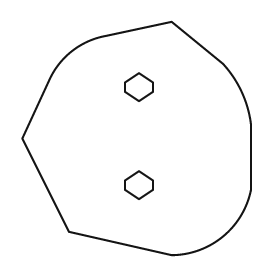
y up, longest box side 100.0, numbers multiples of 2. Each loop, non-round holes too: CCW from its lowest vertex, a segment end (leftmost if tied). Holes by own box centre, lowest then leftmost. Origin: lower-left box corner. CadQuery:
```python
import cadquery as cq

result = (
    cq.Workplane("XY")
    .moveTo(64.0, 0.0)
    .threePointArc((86.0, 8.0), (98.0, 28.0))
    .lineTo(98.0, 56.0)
    .threePointArc((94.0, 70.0), (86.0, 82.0))
    .lineTo(64.0, 100.0)
    .lineTo(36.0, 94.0)
    .threePointArc((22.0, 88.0), (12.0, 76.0))
    .lineTo(0.0, 50.0)
    .lineTo(20.0, 10.0)
    .close()
    .moveTo(50.0, 24.0)
    .lineTo(56.0, 28.0)
    .lineTo(56.0, 32.0)
    .lineTo(50.0, 36.0)
    .lineTo(44.0, 32.0)
    .lineTo(44.0, 28.0)
    .close()
    .moveTo(50.0, 66.0)
    .lineTo(56.0, 70.0)
    .lineTo(56.0, 74.0)
    .lineTo(50.0, 78.0)
    .lineTo(44.0, 74.0)
    .lineTo(44.0, 70.0)
    .close()
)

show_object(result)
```